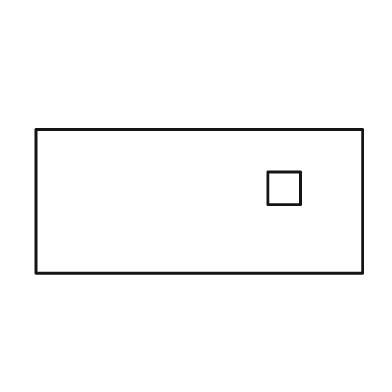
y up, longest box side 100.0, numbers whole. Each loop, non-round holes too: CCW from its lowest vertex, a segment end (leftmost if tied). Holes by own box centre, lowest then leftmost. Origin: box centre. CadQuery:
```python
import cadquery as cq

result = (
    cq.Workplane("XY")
    .moveTo(-50.0, -22.0)
    .lineTo(50.0, -22.0)
    .lineTo(50.0, 22.0)
    .lineTo(-50.0, 22.0)
    .close()
    .moveTo(21.0, -1.0)
    .lineTo(31.0, -1.0)
    .lineTo(31.0, 9.0)
    .lineTo(21.0, 9.0)
    .close()
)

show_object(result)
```